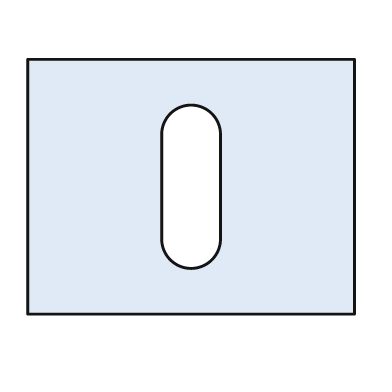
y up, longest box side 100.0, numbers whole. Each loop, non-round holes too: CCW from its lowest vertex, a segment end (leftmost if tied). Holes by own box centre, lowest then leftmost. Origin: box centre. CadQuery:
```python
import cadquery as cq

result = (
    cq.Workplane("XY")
    .moveTo(-50.0, -39.0)
    .lineTo(50.0, -39.0)
    .lineTo(50.0, 39.0)
    .lineTo(-50.0, 39.0)
    .close()
    .moveTo(-9.0, -16.0)
    .threePointArc((0.0, -25.0), (9.0, -16.0))
    .lineTo(9.0, 16.0)
    .threePointArc((0.0, 25.0), (-9.0, 16.0))
    .close()
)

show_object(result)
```